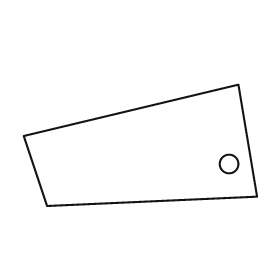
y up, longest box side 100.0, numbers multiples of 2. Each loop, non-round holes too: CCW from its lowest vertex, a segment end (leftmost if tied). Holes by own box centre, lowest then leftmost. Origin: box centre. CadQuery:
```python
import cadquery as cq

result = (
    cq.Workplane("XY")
    .moveTo(-40.0, -26.0)
    .lineTo(50.0, -22.0)
    .lineTo(42.0, 26.0)
    .lineTo(-50.0, 4.0)
    .close()
    .moveTo(38.0, -8.0)
    .circle(4.0)
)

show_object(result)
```